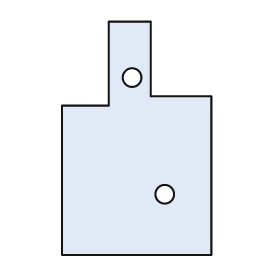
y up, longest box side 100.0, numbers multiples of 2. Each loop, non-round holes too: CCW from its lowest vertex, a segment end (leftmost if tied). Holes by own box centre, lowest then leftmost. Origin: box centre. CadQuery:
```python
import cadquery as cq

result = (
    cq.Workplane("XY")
    .moveTo(-32.0, -50.0)
    .lineTo(32.0, -50.0)
    .lineTo(32.0, 18.0)
    .lineTo(6.0, 18.0)
    .lineTo(6.0, 50.0)
    .lineTo(-12.0, 50.0)
    .lineTo(-12.0, 14.0)
    .lineTo(-32.0, 14.0)
    .close()
    .moveTo(12.0, -24.0)
    .circle(4.0)
    .moveTo(-2.0, 26.0)
    .circle(4.0)
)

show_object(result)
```